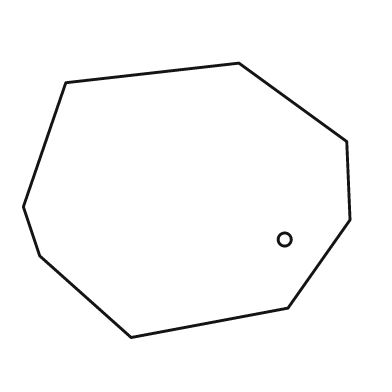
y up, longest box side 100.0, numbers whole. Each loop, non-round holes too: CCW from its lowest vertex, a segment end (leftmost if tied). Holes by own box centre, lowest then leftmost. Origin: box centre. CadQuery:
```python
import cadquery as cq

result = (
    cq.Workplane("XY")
    .moveTo(-17.0, -42.0)
    .lineTo(31.0, -33.0)
    .lineTo(50.0, -6.0)
    .lineTo(49.0, 18.0)
    .lineTo(16.0, 42.0)
    .lineTo(-37.0, 36.0)
    .lineTo(-50.0, -2.0)
    .lineTo(-45.0, -17.0)
    .close()
    .moveTo(30.0, -12.0)
    .circle(2.0)
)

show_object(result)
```